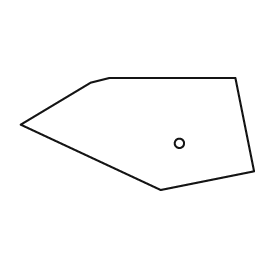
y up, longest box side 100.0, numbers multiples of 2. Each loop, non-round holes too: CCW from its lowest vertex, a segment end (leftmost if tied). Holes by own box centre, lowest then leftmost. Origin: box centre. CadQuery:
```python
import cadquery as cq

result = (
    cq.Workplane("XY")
    .moveTo(10.0, -24.0)
    .lineTo(50.0, -16.0)
    .lineTo(42.0, 24.0)
    .lineTo(-12.0, 24.0)
    .lineTo(-20.0, 22.0)
    .lineTo(-50.0, 4.0)
    .close()
    .moveTo(18.0, -4.0)
    .circle(2.0)
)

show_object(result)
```